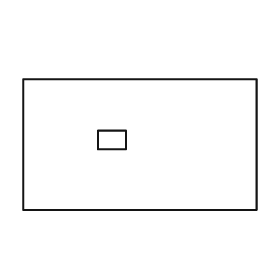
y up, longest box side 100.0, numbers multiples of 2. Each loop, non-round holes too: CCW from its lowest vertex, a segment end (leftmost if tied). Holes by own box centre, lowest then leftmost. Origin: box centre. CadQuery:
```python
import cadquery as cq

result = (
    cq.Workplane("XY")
    .moveTo(-50.0, -28.0)
    .lineTo(50.0, -28.0)
    .lineTo(50.0, 28.0)
    .lineTo(-50.0, 28.0)
    .close()
    .moveTo(-18.0, -2.0)
    .lineTo(-6.0, -2.0)
    .lineTo(-6.0, 6.0)
    .lineTo(-18.0, 6.0)
    .close()
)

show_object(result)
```